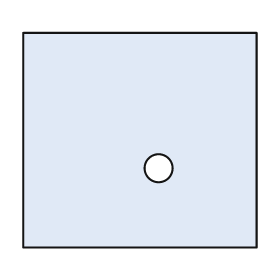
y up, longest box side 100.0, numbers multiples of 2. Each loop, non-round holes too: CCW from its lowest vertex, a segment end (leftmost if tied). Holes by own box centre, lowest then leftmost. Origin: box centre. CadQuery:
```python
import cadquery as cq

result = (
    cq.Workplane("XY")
    .moveTo(-50.0, -46.0)
    .lineTo(50.0, -46.0)
    .lineTo(50.0, 46.0)
    .lineTo(-50.0, 46.0)
    .close()
    .moveTo(8.0, -12.0)
    .circle(6.0)
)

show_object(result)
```